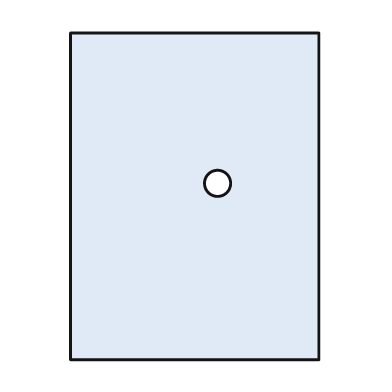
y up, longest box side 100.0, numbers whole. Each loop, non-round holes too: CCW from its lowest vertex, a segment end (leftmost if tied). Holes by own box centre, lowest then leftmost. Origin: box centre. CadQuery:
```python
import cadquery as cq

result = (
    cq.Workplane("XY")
    .moveTo(-38.0, -50.0)
    .lineTo(38.0, -50.0)
    .lineTo(38.0, 50.0)
    .lineTo(-38.0, 50.0)
    .close()
    .moveTo(7.0, 4.0)
    .circle(4.0)
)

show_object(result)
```